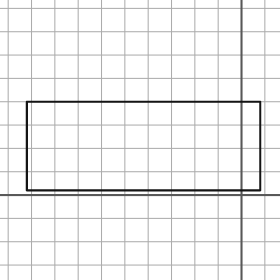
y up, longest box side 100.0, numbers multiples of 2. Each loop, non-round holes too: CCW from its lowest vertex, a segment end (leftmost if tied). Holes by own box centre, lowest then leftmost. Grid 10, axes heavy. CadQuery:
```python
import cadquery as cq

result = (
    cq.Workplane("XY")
    .moveTo(-92.0, 2.0)
    .lineTo(8.0, 2.0)
    .lineTo(8.0, 40.0)
    .lineTo(-92.0, 40.0)
    .close()
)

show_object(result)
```